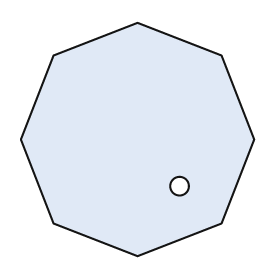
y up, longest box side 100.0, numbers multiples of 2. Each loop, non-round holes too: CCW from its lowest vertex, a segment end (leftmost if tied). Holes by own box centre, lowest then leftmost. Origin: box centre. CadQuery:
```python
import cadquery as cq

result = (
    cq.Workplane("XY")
    .moveTo(0.0, -50.0)
    .lineTo(36.0, -36.0)
    .lineTo(50.0, 0.0)
    .lineTo(36.0, 36.0)
    .lineTo(0.0, 50.0)
    .lineTo(-36.0, 36.0)
    .lineTo(-50.0, 0.0)
    .lineTo(-36.0, -36.0)
    .close()
    .moveTo(18.0, -20.0)
    .circle(4.0)
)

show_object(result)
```